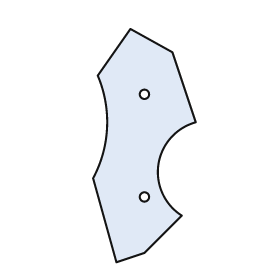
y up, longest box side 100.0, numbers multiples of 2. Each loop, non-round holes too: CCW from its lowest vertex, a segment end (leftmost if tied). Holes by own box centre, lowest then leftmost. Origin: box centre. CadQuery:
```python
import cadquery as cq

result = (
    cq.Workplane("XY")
    .moveTo(-12.0, -50.0)
    .lineTo(0.0, -46.0)
    .lineTo(16.0, -30.0)
    .threePointArc((6.0, -8.0), (22.0, 10.0))
    .lineTo(12.0, 40.0)
    .lineTo(-6.0, 50.0)
    .lineTo(-20.0, 30.0)
    .threePointArc((-16.0, 8.0), (-22.0, -14.0))
    .close()
    .moveTo(0.0, -22.0)
    .circle(2.0)
    .moveTo(0.0, 22.0)
    .circle(2.0)
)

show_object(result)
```